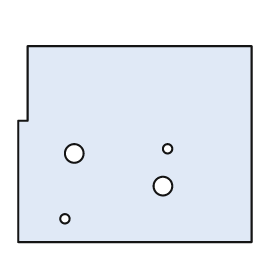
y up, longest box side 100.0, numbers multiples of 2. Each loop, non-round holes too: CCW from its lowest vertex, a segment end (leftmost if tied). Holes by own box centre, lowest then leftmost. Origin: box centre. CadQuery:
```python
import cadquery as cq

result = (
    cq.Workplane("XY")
    .moveTo(-50.0, -42.0)
    .lineTo(50.0, -42.0)
    .lineTo(50.0, 42.0)
    .lineTo(-46.0, 42.0)
    .lineTo(-46.0, 10.0)
    .lineTo(-50.0, 10.0)
    .close()
    .moveTo(-30.0, -32.0)
    .circle(2.0)
    .moveTo(12.0, -18.0)
    .circle(4.0)
    .moveTo(-26.0, -4.0)
    .circle(4.0)
    .moveTo(14.0, -2.0)
    .circle(2.0)
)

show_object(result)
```